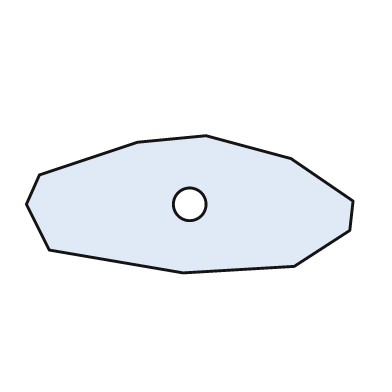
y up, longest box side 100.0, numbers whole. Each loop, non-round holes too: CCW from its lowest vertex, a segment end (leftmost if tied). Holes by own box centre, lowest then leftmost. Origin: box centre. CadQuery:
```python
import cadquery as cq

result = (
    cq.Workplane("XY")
    .moveTo(-2.0, -21.0)
    .lineTo(32.0, -19.0)
    .lineTo(49.0, -8.0)
    .lineTo(50.0, 1.0)
    .lineTo(31.0, 14.0)
    .lineTo(5.0, 21.0)
    .lineTo(-16.0, 19.0)
    .lineTo(-46.0, 9.0)
    .lineTo(-50.0, 0.0)
    .lineTo(-43.0, -14.0)
    .close()
    .moveTo(0.0, 0.0)
    .circle(5.0)
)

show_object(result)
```